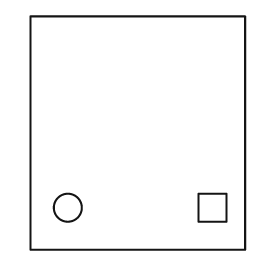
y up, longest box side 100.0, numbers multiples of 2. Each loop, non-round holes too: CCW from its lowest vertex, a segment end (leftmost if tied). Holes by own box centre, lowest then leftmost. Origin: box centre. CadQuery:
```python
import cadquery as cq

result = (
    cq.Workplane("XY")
    .moveTo(-46.0, -50.0)
    .lineTo(46.0, -50.0)
    .lineTo(46.0, 50.0)
    .lineTo(-46.0, 50.0)
    .close()
    .moveTo(-30.0, -32.0)
    .circle(6.0)
    .moveTo(26.0, -38.0)
    .lineTo(38.0, -38.0)
    .lineTo(38.0, -26.0)
    .lineTo(26.0, -26.0)
    .close()
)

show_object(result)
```